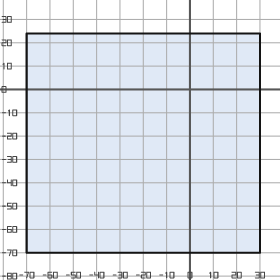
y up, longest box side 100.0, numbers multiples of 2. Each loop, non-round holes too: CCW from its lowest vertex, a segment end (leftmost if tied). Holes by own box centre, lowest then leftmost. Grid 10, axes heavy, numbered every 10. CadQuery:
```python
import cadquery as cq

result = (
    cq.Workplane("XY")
    .moveTo(-70.0, -70.0)
    .lineTo(30.0, -70.0)
    .lineTo(30.0, 24.0)
    .lineTo(-70.0, 24.0)
    .close()
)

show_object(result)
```